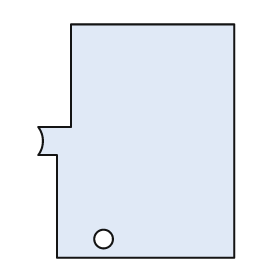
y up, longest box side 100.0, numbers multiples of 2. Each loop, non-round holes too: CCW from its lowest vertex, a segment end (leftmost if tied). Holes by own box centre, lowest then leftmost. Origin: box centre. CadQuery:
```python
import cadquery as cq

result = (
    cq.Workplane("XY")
    .moveTo(-34.0, -50.0)
    .lineTo(42.0, -50.0)
    .lineTo(42.0, 50.0)
    .lineTo(-28.0, 50.0)
    .lineTo(-28.0, 6.0)
    .lineTo(-42.0, 6.0)
    .threePointArc((-40.0, 0.0), (-42.0, -6.0))
    .lineTo(-34.0, -6.0)
    .close()
    .moveTo(-14.0, -42.0)
    .circle(4.0)
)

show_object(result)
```